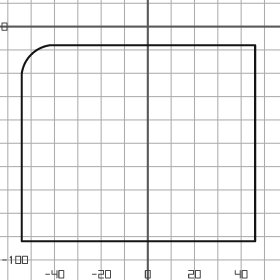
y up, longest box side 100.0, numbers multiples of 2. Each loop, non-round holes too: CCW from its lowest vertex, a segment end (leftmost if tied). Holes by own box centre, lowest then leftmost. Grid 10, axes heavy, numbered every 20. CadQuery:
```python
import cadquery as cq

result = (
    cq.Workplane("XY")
    .moveTo(-54.0, -92.0)
    .lineTo(46.0, -92.0)
    .lineTo(46.0, -8.0)
    .lineTo(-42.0, -8.0)
    .threePointArc((-50.0, -12.0), (-54.0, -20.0))
    .close()
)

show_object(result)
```